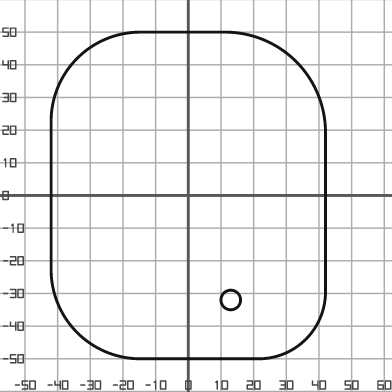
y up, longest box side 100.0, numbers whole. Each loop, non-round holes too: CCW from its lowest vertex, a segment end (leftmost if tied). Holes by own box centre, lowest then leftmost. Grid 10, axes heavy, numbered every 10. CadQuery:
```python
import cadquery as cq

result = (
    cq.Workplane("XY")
    .moveTo(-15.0, -50.0)
    .lineTo(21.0, -50.0)
    .threePointArc((36.0, -44.0), (42.0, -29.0))
    .lineTo(42.0, 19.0)
    .threePointArc((33.0, 41.0), (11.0, 50.0))
    .lineTo(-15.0, 50.0)
    .threePointArc((-34.0, 42.0), (-42.0, 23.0))
    .lineTo(-42.0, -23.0)
    .threePointArc((-34.0, -42.0), (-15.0, -50.0))
    .close()
    .moveTo(13.0, -32.0)
    .circle(3.0)
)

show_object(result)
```